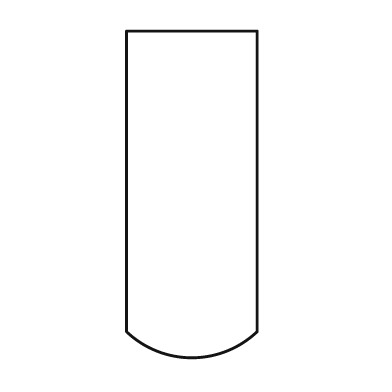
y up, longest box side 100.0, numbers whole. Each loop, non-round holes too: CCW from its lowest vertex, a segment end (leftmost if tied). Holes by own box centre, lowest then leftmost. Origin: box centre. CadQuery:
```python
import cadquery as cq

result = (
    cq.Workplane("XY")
    .moveTo(-20.0, -42.0)
    .threePointArc((0.0, -50.0), (20.0, -42.0))
    .lineTo(20.0, 50.0)
    .lineTo(-20.0, 50.0)
    .close()
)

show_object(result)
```